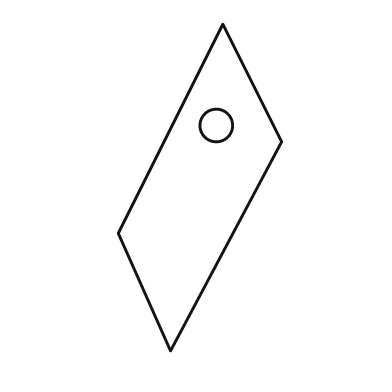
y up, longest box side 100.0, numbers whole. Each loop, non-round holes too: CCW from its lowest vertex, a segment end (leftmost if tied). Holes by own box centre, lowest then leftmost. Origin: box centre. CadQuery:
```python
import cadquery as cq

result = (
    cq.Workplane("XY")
    .moveTo(-9.0, -50.0)
    .lineTo(25.0, 14.0)
    .lineTo(7.0, 50.0)
    .lineTo(-25.0, -14.0)
    .close()
    .moveTo(5.0, 19.0)
    .circle(5.0)
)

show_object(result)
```